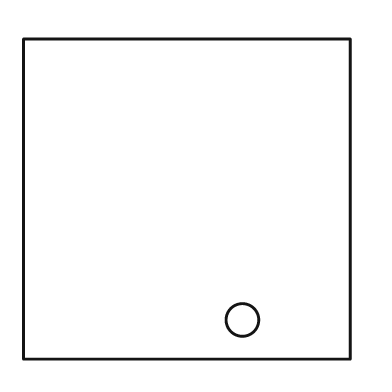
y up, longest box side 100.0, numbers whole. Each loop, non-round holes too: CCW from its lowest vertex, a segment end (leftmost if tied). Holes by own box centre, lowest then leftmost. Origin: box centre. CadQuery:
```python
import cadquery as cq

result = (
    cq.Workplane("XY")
    .moveTo(-50.0, -49.0)
    .lineTo(50.0, -49.0)
    .lineTo(50.0, 49.0)
    .lineTo(-50.0, 49.0)
    .close()
    .moveTo(17.0, -37.0)
    .circle(5.0)
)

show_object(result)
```